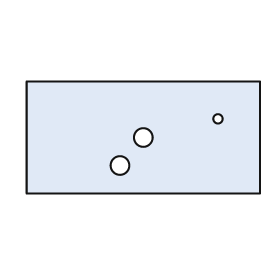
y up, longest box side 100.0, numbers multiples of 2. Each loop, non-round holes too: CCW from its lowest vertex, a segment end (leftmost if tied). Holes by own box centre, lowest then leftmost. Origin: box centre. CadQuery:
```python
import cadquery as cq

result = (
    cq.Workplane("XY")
    .moveTo(-50.0, -24.0)
    .lineTo(50.0, -24.0)
    .lineTo(50.0, 24.0)
    .lineTo(-50.0, 24.0)
    .close()
    .moveTo(-10.0, -12.0)
    .circle(4.0)
    .moveTo(0.0, 0.0)
    .circle(4.0)
    .moveTo(32.0, 8.0)
    .circle(2.0)
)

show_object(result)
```